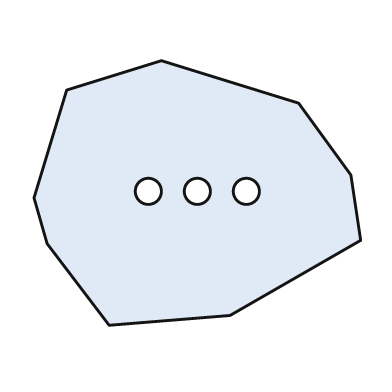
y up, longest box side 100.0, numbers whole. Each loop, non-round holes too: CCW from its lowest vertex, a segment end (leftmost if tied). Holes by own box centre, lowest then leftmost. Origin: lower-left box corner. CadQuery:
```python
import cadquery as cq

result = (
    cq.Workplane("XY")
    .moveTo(23.0, 0.0)
    .lineTo(60.0, 3.0)
    .lineTo(100.0, 26.0)
    .lineTo(97.0, 46.0)
    .lineTo(81.0, 68.0)
    .lineTo(39.0, 81.0)
    .lineTo(10.0, 72.0)
    .lineTo(0.0, 39.0)
    .lineTo(4.0, 25.0)
    .close()
    .moveTo(35.0, 41.0)
    .circle(4.0)
    .moveTo(50.0, 41.0)
    .circle(4.0)
    .moveTo(65.0, 41.0)
    .circle(4.0)
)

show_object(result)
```